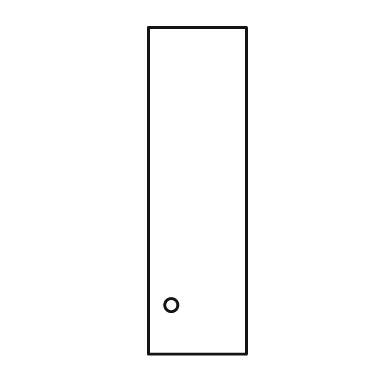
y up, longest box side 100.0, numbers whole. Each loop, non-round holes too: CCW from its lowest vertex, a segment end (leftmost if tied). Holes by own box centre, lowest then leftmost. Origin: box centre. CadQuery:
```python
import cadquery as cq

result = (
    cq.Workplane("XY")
    .moveTo(-15.0, -50.0)
    .lineTo(15.0, -50.0)
    .lineTo(15.0, 50.0)
    .lineTo(-15.0, 50.0)
    .close()
    .moveTo(-8.0, -35.0)
    .circle(2.0)
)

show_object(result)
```